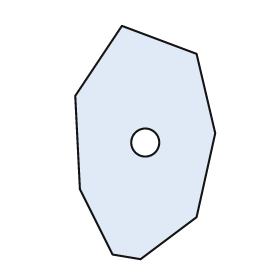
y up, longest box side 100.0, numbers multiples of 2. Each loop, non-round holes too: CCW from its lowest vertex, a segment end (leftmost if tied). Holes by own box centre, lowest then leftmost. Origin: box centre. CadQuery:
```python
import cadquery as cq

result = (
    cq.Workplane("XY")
    .moveTo(-2.0, -50.0)
    .lineTo(22.0, -32.0)
    .lineTo(30.0, 4.0)
    .lineTo(22.0, 38.0)
    .lineTo(-10.0, 50.0)
    .lineTo(-30.0, 20.0)
    .lineTo(-28.0, -20.0)
    .lineTo(-14.0, -48.0)
    .close()
    .moveTo(0.0, 0.0)
    .circle(6.0)
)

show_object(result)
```